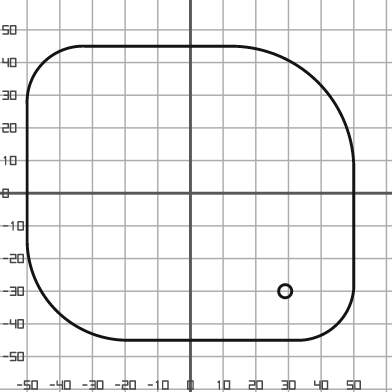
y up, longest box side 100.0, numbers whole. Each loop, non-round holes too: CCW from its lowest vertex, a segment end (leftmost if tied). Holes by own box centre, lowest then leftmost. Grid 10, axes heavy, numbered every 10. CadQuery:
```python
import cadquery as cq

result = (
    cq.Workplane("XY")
    .moveTo(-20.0, -45.0)
    .lineTo(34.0, -45.0)
    .threePointArc((45.0, -40.0), (50.0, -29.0))
    .lineTo(50.0, 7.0)
    .threePointArc((39.0, 34.0), (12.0, 45.0))
    .lineTo(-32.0, 45.0)
    .threePointArc((-45.0, 40.0), (-50.0, 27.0))
    .lineTo(-50.0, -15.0)
    .threePointArc((-41.0, -36.0), (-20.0, -45.0))
    .close()
    .moveTo(29.0, -30.0)
    .circle(2.0)
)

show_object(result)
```